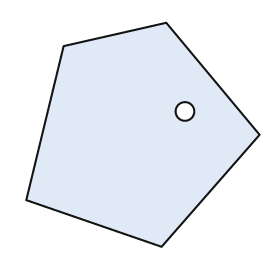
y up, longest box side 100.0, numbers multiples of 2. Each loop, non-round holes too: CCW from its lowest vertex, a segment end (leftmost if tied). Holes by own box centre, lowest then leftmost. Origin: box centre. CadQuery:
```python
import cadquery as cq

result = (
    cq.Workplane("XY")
    .moveTo(8.0, -48.0)
    .lineTo(50.0, 0.0)
    .lineTo(10.0, 48.0)
    .lineTo(-34.0, 38.0)
    .lineTo(-50.0, -28.0)
    .close()
    .moveTo(18.0, 10.0)
    .circle(4.0)
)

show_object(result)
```